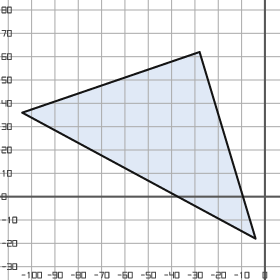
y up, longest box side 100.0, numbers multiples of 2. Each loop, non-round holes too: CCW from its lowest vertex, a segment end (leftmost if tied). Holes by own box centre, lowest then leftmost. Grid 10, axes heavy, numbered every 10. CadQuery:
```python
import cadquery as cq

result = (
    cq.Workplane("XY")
    .moveTo(-4.0, -18.0)
    .lineTo(-28.0, 62.0)
    .lineTo(-104.0, 36.0)
    .close()
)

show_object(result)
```